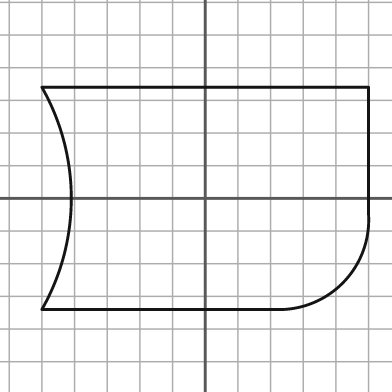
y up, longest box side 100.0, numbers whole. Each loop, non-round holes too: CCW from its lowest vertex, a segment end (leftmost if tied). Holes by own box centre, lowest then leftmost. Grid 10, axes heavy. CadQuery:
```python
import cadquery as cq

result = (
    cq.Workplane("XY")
    .moveTo(-50.0, -34.0)
    .lineTo(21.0, -34.0)
    .threePointArc((42.0, -26.0), (50.0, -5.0))
    .lineTo(50.0, 34.0)
    .lineTo(-50.0, 34.0)
    .threePointArc((-41.0, 0.0), (-50.0, -34.0))
    .close()
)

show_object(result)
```